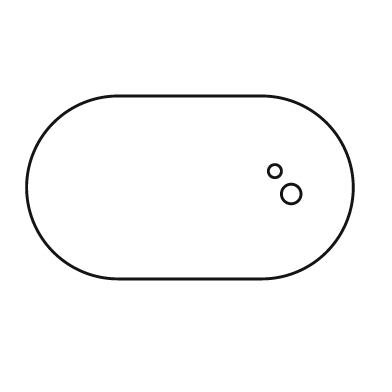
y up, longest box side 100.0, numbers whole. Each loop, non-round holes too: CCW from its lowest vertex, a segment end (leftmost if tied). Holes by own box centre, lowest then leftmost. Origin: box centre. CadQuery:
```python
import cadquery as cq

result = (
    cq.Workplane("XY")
    .moveTo(-22.0, -28.0)
    .lineTo(22.0, -28.0)
    .threePointArc((50.0, 0.0), (22.0, 28.0))
    .lineTo(-22.0, 28.0)
    .threePointArc((-50.0, 0.0), (-22.0, -28.0))
    .close()
    .moveTo(31.0, -2.0)
    .circle(3.0)
    .moveTo(26.0, 5.0)
    .circle(2.0)
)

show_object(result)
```